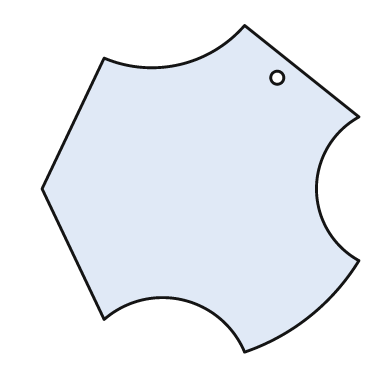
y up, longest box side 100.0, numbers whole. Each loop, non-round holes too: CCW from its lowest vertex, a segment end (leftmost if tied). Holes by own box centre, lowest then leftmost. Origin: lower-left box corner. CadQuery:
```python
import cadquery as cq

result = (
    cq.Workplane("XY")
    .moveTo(62.0, 0.0)
    .threePointArc((82.0, 11.0), (97.0, 28.0))
    .threePointArc((84.0, 50.0), (97.0, 72.0))
    .lineTo(62.0, 100.0)
    .threePointArc((42.0, 88.0), (19.0, 90.0))
    .lineTo(0.0, 50.0)
    .lineTo(19.0, 10.0)
    .threePointArc((43.0, 16.0), (62.0, 0.0))
    .close()
    .moveTo(72.0, 84.0)
    .circle(2.0)
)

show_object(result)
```